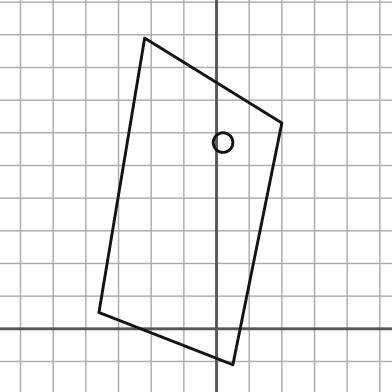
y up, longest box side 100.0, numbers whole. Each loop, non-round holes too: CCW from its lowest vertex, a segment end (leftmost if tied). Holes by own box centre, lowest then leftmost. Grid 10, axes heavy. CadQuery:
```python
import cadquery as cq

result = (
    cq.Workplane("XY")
    .moveTo(5.0, -11.0)
    .lineTo(20.0, 63.0)
    .lineTo(-22.0, 89.0)
    .lineTo(-36.0, 5.0)
    .close()
    .moveTo(2.0, 57.0)
    .circle(3.0)
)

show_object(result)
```